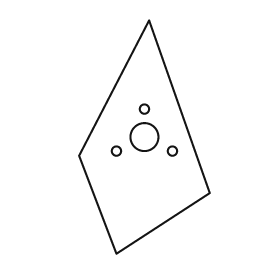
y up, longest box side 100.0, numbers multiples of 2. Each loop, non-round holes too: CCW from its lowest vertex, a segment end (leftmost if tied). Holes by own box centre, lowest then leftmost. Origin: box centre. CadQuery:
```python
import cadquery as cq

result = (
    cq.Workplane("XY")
    .moveTo(-12.0, -50.0)
    .lineTo(28.0, -24.0)
    .lineTo(2.0, 50.0)
    .lineTo(-28.0, -8.0)
    .close()
    .moveTo(-12.0, -6.0)
    .circle(2.0)
    .moveTo(12.0, -6.0)
    .circle(2.0)
    .moveTo(0.0, 0.0)
    .circle(6.0)
    .moveTo(0.0, 12.0)
    .circle(2.0)
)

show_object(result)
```